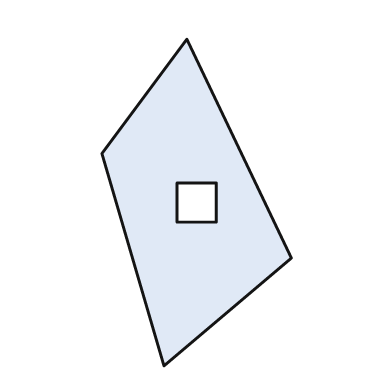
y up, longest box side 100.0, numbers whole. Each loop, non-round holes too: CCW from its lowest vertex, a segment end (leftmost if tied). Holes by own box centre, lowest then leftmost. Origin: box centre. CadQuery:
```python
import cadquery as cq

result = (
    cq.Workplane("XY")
    .moveTo(-10.0, -50.0)
    .lineTo(29.0, -17.0)
    .lineTo(-3.0, 50.0)
    .lineTo(-29.0, 15.0)
    .close()
    .moveTo(-6.0, -6.0)
    .lineTo(6.0, -6.0)
    .lineTo(6.0, 6.0)
    .lineTo(-6.0, 6.0)
    .close()
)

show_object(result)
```